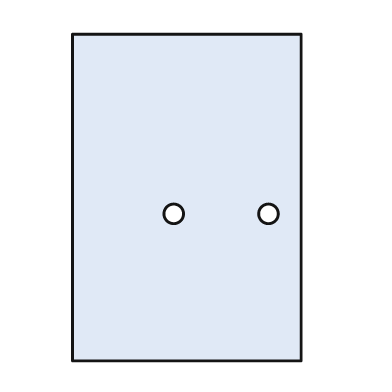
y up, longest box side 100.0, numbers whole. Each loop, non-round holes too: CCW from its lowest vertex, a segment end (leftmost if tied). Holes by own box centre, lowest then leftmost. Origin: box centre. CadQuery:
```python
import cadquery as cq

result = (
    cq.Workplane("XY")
    .moveTo(-35.0, -50.0)
    .lineTo(35.0, -50.0)
    .lineTo(35.0, 50.0)
    .lineTo(-35.0, 50.0)
    .close()
    .moveTo(-4.0, -5.0)
    .circle(3.0)
    .moveTo(25.0, -5.0)
    .circle(3.0)
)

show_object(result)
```